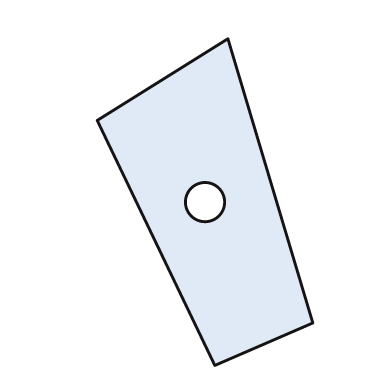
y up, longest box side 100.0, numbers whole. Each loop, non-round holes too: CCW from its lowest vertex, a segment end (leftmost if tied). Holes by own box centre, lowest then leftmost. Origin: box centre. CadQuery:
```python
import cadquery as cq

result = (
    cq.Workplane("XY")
    .moveTo(3.0, -50.0)
    .lineTo(33.0, -37.0)
    .lineTo(7.0, 50.0)
    .lineTo(-33.0, 25.0)
    .close()
    .moveTo(0.0, 0.0)
    .circle(6.0)
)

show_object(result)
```